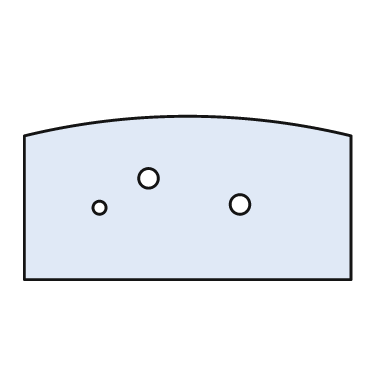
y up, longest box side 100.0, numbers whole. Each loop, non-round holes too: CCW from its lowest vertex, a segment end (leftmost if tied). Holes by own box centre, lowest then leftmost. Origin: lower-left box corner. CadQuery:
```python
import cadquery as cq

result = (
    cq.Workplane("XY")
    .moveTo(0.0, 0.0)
    .lineTo(100.0, 0.0)
    .lineTo(100.0, 44.0)
    .threePointArc((50.0, 50.0), (0.0, 44.0))
    .close()
    .moveTo(23.0, 22.0)
    .circle(2.0)
    .moveTo(66.0, 23.0)
    .circle(3.0)
    .moveTo(38.0, 31.0)
    .circle(3.0)
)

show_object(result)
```